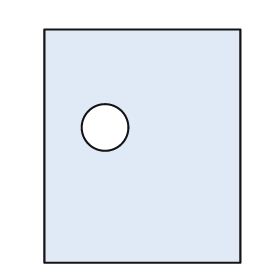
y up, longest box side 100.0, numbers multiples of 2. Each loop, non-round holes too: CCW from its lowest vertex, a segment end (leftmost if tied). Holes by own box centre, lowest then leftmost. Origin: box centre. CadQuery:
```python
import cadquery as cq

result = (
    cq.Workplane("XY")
    .moveTo(-42.0, -50.0)
    .lineTo(42.0, -50.0)
    .lineTo(42.0, 50.0)
    .lineTo(-42.0, 50.0)
    .close()
    .moveTo(-16.0, 8.0)
    .circle(10.0)
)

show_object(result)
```